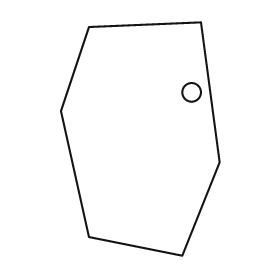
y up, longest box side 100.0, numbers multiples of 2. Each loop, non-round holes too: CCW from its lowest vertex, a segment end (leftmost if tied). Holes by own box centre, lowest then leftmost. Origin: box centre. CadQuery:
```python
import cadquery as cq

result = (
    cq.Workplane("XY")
    .moveTo(18.0, -50.0)
    .lineTo(34.0, -10.0)
    .lineTo(26.0, 50.0)
    .lineTo(-22.0, 48.0)
    .lineTo(-34.0, 12.0)
    .lineTo(-22.0, -42.0)
    .close()
    .moveTo(22.0, 20.0)
    .circle(4.0)
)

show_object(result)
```